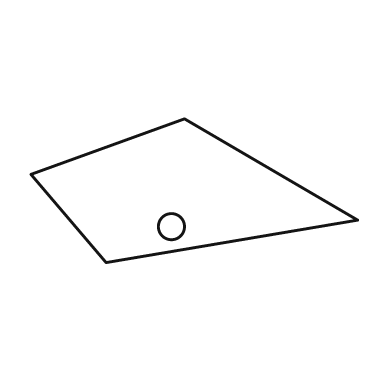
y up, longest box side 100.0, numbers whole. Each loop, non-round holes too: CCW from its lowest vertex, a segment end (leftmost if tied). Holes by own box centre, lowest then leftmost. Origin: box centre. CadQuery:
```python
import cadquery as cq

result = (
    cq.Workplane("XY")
    .moveTo(-27.0, -22.0)
    .lineTo(50.0, -9.0)
    .lineTo(-3.0, 22.0)
    .lineTo(-50.0, 5.0)
    .close()
    .moveTo(-7.0, -11.0)
    .circle(4.0)
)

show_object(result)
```